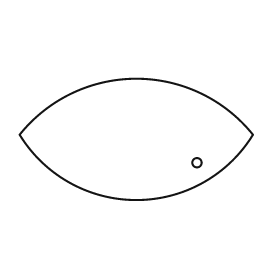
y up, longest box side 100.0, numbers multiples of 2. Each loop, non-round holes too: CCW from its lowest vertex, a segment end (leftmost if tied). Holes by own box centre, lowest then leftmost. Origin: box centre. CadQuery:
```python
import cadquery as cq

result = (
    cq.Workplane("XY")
    .moveTo(-50.0, 2.0)
    .threePointArc((0.0, -26.0), (50.0, 2.0))
    .threePointArc((0.0, 26.0), (-50.0, 2.0))
    .close()
    .moveTo(26.0, -10.0)
    .circle(2.0)
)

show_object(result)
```